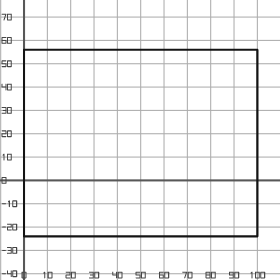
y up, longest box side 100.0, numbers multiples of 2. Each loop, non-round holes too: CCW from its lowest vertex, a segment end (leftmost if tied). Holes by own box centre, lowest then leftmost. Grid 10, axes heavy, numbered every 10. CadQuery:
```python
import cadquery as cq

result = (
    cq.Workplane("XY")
    .moveTo(0.0, -24.0)
    .lineTo(100.0, -24.0)
    .lineTo(100.0, 56.0)
    .lineTo(0.0, 56.0)
    .close()
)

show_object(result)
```